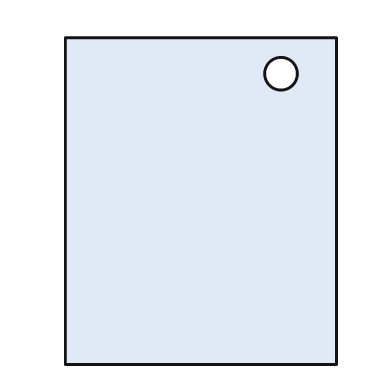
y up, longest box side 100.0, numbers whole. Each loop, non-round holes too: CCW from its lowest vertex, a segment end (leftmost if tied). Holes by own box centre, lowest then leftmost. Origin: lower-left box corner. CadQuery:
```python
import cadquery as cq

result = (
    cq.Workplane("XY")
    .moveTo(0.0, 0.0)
    .lineTo(83.0, 0.0)
    .lineTo(83.0, 100.0)
    .lineTo(0.0, 100.0)
    .close()
    .moveTo(66.0, 89.0)
    .circle(5.0)
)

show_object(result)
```